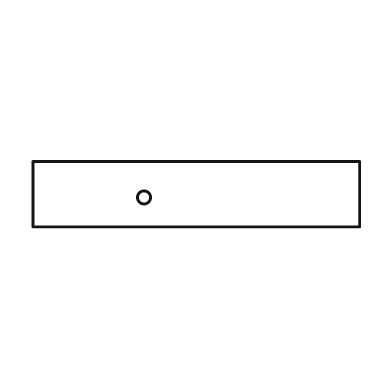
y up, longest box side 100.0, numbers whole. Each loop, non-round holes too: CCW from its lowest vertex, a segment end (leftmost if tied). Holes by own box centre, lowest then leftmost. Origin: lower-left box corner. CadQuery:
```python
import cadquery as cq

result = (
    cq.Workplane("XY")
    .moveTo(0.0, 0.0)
    .lineTo(100.0, 0.0)
    .lineTo(100.0, 20.0)
    .lineTo(0.0, 20.0)
    .close()
    .moveTo(34.0, 9.0)
    .circle(2.0)
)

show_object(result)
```